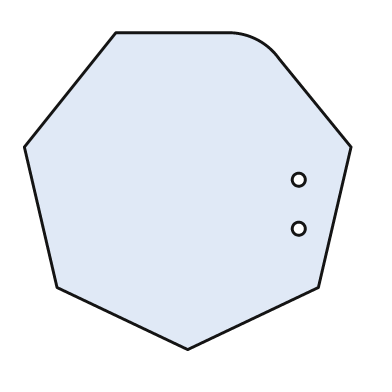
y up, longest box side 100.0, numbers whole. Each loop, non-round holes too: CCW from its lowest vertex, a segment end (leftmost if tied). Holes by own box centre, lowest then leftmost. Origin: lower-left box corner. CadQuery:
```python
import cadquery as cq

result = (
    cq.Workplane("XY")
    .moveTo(50.0, 0.0)
    .lineTo(90.0, 19.0)
    .lineTo(100.0, 62.0)
    .lineTo(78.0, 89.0)
    .threePointArc((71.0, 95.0), (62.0, 97.0))
    .lineTo(28.0, 97.0)
    .lineTo(0.0, 62.0)
    .lineTo(10.0, 19.0)
    .close()
    .moveTo(84.0, 37.0)
    .circle(2.0)
    .moveTo(84.0, 52.0)
    .circle(2.0)
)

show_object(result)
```